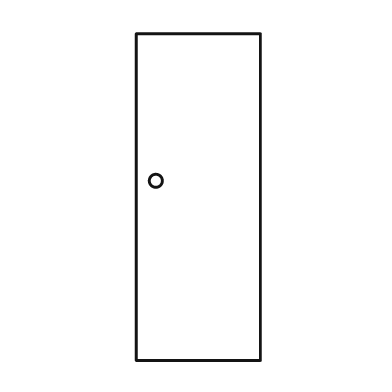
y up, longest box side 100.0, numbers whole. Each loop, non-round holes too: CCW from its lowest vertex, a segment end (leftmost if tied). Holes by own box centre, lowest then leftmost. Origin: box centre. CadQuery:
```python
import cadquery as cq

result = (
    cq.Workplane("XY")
    .moveTo(-19.0, -50.0)
    .lineTo(19.0, -50.0)
    .lineTo(19.0, 50.0)
    .lineTo(-19.0, 50.0)
    .close()
    .moveTo(-13.0, 5.0)
    .circle(2.0)
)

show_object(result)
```